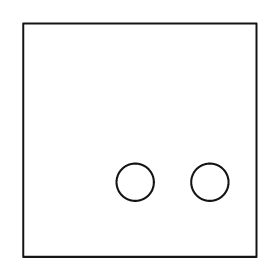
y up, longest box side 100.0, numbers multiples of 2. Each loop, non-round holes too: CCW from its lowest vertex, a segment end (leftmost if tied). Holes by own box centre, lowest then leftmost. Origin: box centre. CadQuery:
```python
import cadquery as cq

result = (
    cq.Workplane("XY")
    .moveTo(-50.0, -50.0)
    .lineTo(50.0, -50.0)
    .lineTo(50.0, 50.0)
    .lineTo(-50.0, 50.0)
    .close()
    .moveTo(-2.0, -18.0)
    .circle(8.0)
    .moveTo(30.0, -18.0)
    .circle(8.0)
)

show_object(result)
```